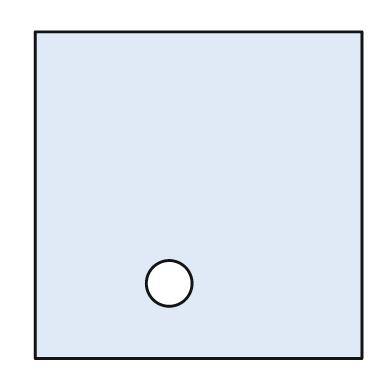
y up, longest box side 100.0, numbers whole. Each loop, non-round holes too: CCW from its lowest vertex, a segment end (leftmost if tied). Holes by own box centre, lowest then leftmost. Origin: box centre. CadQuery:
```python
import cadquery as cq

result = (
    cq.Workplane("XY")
    .moveTo(-50.0, -50.0)
    .lineTo(50.0, -50.0)
    .lineTo(50.0, 50.0)
    .lineTo(-50.0, 50.0)
    .close()
    .moveTo(-9.0, -27.0)
    .circle(7.0)
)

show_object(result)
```